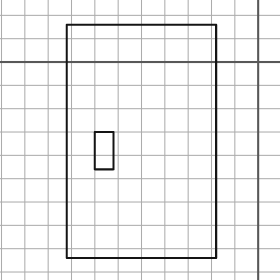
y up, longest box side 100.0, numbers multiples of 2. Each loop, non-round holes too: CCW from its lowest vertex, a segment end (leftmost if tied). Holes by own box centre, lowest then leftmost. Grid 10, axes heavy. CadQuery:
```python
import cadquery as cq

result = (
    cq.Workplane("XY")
    .moveTo(-82.0, -84.0)
    .lineTo(-18.0, -84.0)
    .lineTo(-18.0, 16.0)
    .lineTo(-82.0, 16.0)
    .close()
    .moveTo(-70.0, -46.0)
    .lineTo(-62.0, -46.0)
    .lineTo(-62.0, -30.0)
    .lineTo(-70.0, -30.0)
    .close()
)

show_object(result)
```